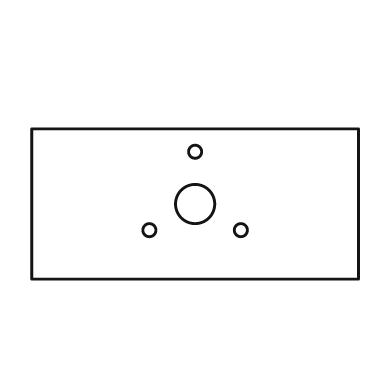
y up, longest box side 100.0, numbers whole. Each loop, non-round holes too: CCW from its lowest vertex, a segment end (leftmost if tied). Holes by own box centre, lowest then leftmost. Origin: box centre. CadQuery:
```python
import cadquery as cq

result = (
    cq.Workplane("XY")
    .moveTo(-50.0, -23.0)
    .lineTo(50.0, -23.0)
    .lineTo(50.0, 23.0)
    .lineTo(-50.0, 23.0)
    .close()
    .moveTo(-14.0, -8.0)
    .circle(2.0)
    .moveTo(14.0, -8.0)
    .circle(2.0)
    .moveTo(0.0, 0.0)
    .circle(6.0)
    .moveTo(0.0, 16.0)
    .circle(2.0)
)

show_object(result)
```